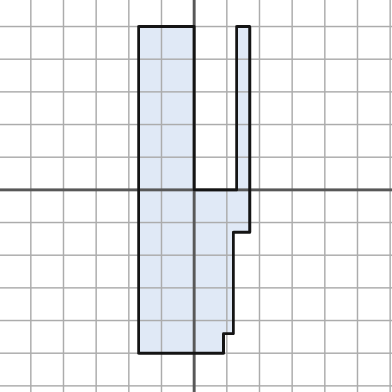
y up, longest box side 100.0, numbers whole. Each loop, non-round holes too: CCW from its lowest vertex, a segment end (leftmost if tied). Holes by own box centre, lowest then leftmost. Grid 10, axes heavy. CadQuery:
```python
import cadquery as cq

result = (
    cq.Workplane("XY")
    .moveTo(-17.0, -50.0)
    .lineTo(9.0, -50.0)
    .lineTo(9.0, -44.0)
    .lineTo(12.0, -44.0)
    .lineTo(12.0, -13.0)
    .lineTo(17.0, -13.0)
    .lineTo(17.0, 50.0)
    .lineTo(13.0, 50.0)
    .lineTo(13.0, 0.0)
    .lineTo(0.0, 0.0)
    .lineTo(0.0, 50.0)
    .lineTo(-17.0, 50.0)
    .close()
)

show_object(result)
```